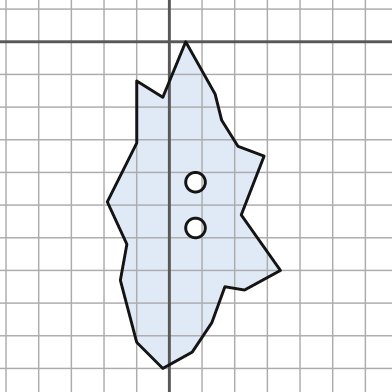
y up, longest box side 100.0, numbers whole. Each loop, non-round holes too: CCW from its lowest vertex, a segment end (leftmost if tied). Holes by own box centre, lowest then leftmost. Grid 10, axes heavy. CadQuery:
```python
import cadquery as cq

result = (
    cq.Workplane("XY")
    .moveTo(-2.0, -100.0)
    .lineTo(7.0, -95.0)
    .lineTo(13.0, -86.0)
    .lineTo(17.0, -75.0)
    .lineTo(23.0, -76.0)
    .lineTo(34.0, -70.0)
    .lineTo(22.0, -53.0)
    .lineTo(29.0, -35.0)
    .lineTo(21.0, -32.0)
    .lineTo(16.0, -24.0)
    .lineTo(14.0, -16.0)
    .lineTo(5.0, 0.0)
    .lineTo(-2.0, -17.0)
    .lineTo(-10.0, -12.0)
    .lineTo(-10.0, -31.0)
    .lineTo(-19.0, -49.0)
    .lineTo(-13.0, -62.0)
    .lineTo(-15.0, -73.0)
    .lineTo(-10.0, -92.0)
    .close()
    .moveTo(8.0, -57.0)
    .circle(3.0)
    .moveTo(8.0, -43.0)
    .circle(3.0)
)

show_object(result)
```